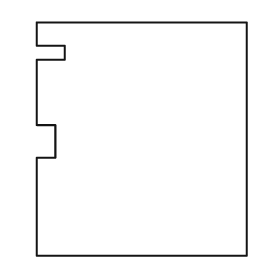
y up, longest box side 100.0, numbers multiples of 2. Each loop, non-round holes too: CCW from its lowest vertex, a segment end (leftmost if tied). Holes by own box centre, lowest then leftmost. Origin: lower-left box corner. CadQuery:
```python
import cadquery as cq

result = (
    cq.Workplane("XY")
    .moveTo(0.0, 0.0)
    .lineTo(90.0, 0.0)
    .lineTo(90.0, 100.0)
    .lineTo(0.0, 100.0)
    .lineTo(0.0, 90.0)
    .lineTo(12.0, 90.0)
    .lineTo(12.0, 84.0)
    .lineTo(0.0, 84.0)
    .lineTo(0.0, 56.0)
    .lineTo(8.0, 56.0)
    .lineTo(8.0, 42.0)
    .lineTo(0.0, 42.0)
    .close()
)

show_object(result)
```